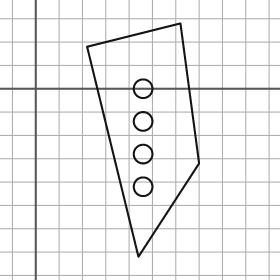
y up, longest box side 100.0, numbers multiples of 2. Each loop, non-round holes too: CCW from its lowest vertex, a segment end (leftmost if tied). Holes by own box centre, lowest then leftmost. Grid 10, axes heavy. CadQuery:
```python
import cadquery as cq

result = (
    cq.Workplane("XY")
    .moveTo(44.0, -72.0)
    .lineTo(70.0, -32.0)
    .lineTo(62.0, 28.0)
    .lineTo(22.0, 18.0)
    .close()
    .moveTo(46.0, -42.0)
    .circle(4.0)
    .moveTo(46.0, -28.0)
    .circle(4.0)
    .moveTo(46.0, -14.0)
    .circle(4.0)
    .moveTo(46.0, 0.0)
    .circle(4.0)
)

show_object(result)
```